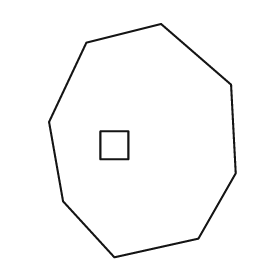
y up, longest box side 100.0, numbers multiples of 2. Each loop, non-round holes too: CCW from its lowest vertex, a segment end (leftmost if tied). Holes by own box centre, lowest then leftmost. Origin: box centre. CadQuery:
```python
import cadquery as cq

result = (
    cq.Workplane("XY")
    .moveTo(-12.0, -50.0)
    .lineTo(24.0, -42.0)
    .lineTo(40.0, -14.0)
    .lineTo(38.0, 24.0)
    .lineTo(8.0, 50.0)
    .lineTo(-24.0, 42.0)
    .lineTo(-40.0, 8.0)
    .lineTo(-34.0, -26.0)
    .close()
    .moveTo(-18.0, -8.0)
    .lineTo(-6.0, -8.0)
    .lineTo(-6.0, 4.0)
    .lineTo(-18.0, 4.0)
    .close()
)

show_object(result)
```